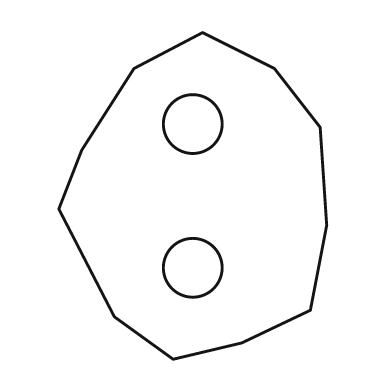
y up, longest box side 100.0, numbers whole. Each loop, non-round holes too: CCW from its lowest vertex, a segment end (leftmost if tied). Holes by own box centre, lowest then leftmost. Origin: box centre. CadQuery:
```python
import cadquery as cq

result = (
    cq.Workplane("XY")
    .moveTo(-6.0, -50.0)
    .lineTo(15.0, -45.0)
    .lineTo(36.0, -35.0)
    .lineTo(41.0, -9.0)
    .lineTo(39.0, 21.0)
    .lineTo(25.0, 39.0)
    .lineTo(3.0, 50.0)
    .lineTo(-18.0, 39.0)
    .lineTo(-34.0, 14.0)
    .lineTo(-41.0, -4.0)
    .lineTo(-24.0, -37.0)
    .close()
    .moveTo(0.0, -22.0)
    .circle(9.0)
    .moveTo(0.0, 22.0)
    .circle(9.0)
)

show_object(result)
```